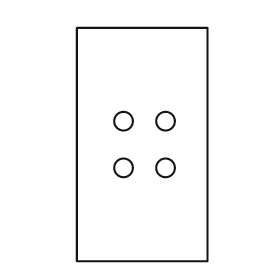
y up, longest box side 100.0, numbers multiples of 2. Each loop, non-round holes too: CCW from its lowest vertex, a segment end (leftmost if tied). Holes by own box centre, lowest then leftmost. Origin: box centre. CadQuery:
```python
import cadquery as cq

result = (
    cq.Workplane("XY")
    .moveTo(-28.0, -50.0)
    .lineTo(28.0, -50.0)
    .lineTo(28.0, 50.0)
    .lineTo(-28.0, 50.0)
    .close()
    .moveTo(-8.0, -10.0)
    .circle(4.0)
    .moveTo(10.0, -10.0)
    .circle(4.0)
    .moveTo(-8.0, 10.0)
    .circle(4.0)
    .moveTo(10.0, 10.0)
    .circle(4.0)
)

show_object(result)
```